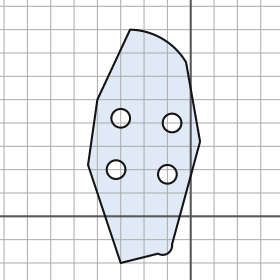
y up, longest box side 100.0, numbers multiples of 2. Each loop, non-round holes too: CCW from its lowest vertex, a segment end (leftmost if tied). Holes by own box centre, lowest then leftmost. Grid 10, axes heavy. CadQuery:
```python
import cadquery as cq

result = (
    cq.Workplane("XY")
    .moveTo(-30.0, -20.0)
    .lineTo(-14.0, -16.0)
    .threePointArc((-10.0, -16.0), (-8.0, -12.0))
    .lineTo(4.0, 32.0)
    .lineTo(-2.0, 66.0)
    .threePointArc((-12.0, 76.0), (-26.0, 80.0))
    .lineTo(-40.0, 50.0)
    .lineTo(-44.0, 22.0)
    .close()
    .moveTo(-10.0, 18.0)
    .circle(4.0)
    .moveTo(-32.0, 20.0)
    .circle(4.0)
    .moveTo(-8.0, 40.0)
    .circle(4.0)
    .moveTo(-30.0, 42.0)
    .circle(4.0)
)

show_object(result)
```